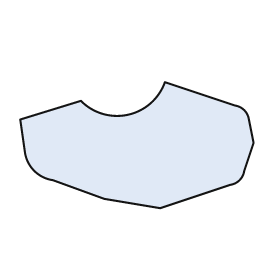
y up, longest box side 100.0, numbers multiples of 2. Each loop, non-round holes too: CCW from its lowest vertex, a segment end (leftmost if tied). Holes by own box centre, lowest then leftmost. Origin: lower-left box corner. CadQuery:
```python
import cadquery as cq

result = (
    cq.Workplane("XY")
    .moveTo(60.0, 0.0)
    .lineTo(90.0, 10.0)
    .threePointArc((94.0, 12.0), (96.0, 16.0))
    .lineTo(100.0, 28.0)
    .lineTo(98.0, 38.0)
    .threePointArc((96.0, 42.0), (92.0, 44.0))
    .lineTo(62.0, 54.0)
    .threePointArc((46.0, 40.0), (26.0, 46.0))
    .lineTo(0.0, 38.0)
    .lineTo(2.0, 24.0)
    .threePointArc((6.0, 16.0), (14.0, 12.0))
    .lineTo(36.0, 4.0)
    .close()
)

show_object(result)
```